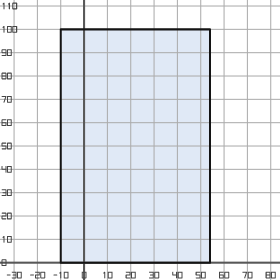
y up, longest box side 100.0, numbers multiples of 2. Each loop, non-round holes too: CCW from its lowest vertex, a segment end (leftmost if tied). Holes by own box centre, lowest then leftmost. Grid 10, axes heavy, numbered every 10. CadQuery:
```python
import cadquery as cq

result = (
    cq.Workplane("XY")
    .moveTo(-10.0, 0.0)
    .lineTo(54.0, 0.0)
    .lineTo(54.0, 100.0)
    .lineTo(-10.0, 100.0)
    .close()
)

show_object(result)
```